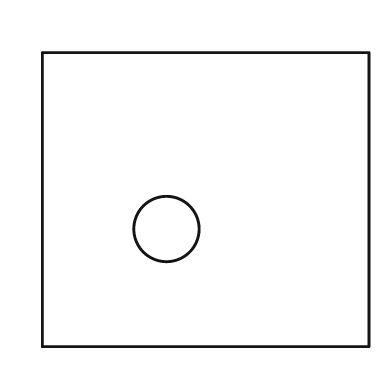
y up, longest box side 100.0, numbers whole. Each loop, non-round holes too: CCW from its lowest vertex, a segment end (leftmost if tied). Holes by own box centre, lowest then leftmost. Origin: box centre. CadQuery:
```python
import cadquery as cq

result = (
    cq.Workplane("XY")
    .moveTo(-50.0, -45.0)
    .lineTo(50.0, -45.0)
    .lineTo(50.0, 45.0)
    .lineTo(-50.0, 45.0)
    .close()
    .moveTo(-12.0, -9.0)
    .circle(10.0)
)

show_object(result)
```